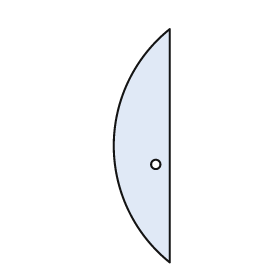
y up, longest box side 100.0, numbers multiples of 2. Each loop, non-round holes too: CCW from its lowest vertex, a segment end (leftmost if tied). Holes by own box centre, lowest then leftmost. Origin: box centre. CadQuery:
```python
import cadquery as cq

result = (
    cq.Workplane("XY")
    .moveTo(12.0, -50.0)
    .lineTo(12.0, 50.0)
    .threePointArc((-12.0, 0.0), (12.0, -50.0))
    .close()
    .moveTo(6.0, -8.0)
    .circle(2.0)
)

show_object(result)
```